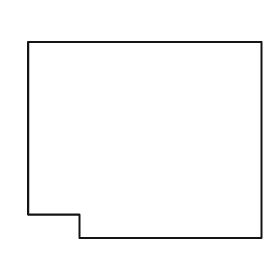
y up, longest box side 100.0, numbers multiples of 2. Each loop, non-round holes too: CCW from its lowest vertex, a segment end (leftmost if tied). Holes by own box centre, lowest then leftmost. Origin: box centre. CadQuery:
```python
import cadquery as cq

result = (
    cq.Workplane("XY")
    .moveTo(-28.0, -42.0)
    .lineTo(50.0, -42.0)
    .lineTo(50.0, 42.0)
    .lineTo(-50.0, 42.0)
    .lineTo(-50.0, -32.0)
    .lineTo(-28.0, -32.0)
    .close()
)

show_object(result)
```